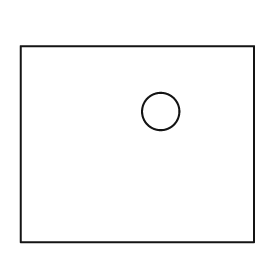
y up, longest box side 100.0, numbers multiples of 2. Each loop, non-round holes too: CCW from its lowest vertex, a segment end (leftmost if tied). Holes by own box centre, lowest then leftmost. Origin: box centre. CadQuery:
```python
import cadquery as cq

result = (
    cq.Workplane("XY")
    .moveTo(-50.0, -42.0)
    .lineTo(50.0, -42.0)
    .lineTo(50.0, 42.0)
    .lineTo(-50.0, 42.0)
    .close()
    .moveTo(10.0, 14.0)
    .circle(8.0)
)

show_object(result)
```